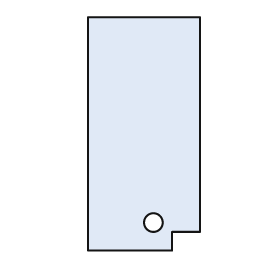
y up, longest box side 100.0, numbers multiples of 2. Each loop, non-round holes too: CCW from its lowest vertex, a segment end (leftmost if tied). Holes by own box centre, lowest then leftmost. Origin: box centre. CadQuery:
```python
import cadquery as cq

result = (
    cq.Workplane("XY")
    .moveTo(-24.0, -50.0)
    .lineTo(12.0, -50.0)
    .lineTo(12.0, -42.0)
    .lineTo(24.0, -42.0)
    .lineTo(24.0, 50.0)
    .lineTo(-24.0, 50.0)
    .close()
    .moveTo(4.0, -38.0)
    .circle(4.0)
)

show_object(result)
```